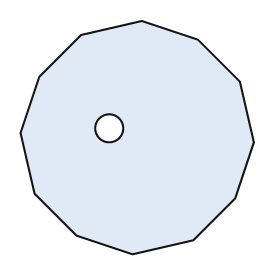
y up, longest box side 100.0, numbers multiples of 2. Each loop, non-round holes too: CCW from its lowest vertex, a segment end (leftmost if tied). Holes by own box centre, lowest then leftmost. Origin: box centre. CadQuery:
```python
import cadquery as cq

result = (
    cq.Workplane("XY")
    .moveTo(-2.0, -50.0)
    .lineTo(24.0, -44.0)
    .lineTo(42.0, -26.0)
    .lineTo(50.0, -2.0)
    .lineTo(44.0, 24.0)
    .lineTo(26.0, 42.0)
    .lineTo(2.0, 50.0)
    .lineTo(-24.0, 44.0)
    .lineTo(-42.0, 26.0)
    .lineTo(-50.0, 2.0)
    .lineTo(-44.0, -24.0)
    .lineTo(-26.0, -42.0)
    .close()
    .moveTo(-12.0, 4.0)
    .circle(6.0)
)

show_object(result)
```